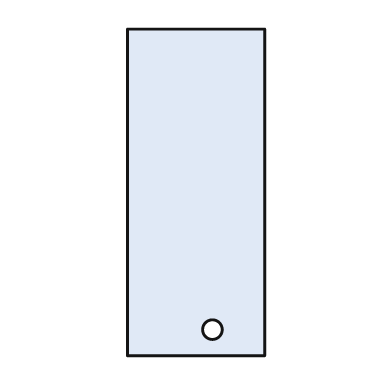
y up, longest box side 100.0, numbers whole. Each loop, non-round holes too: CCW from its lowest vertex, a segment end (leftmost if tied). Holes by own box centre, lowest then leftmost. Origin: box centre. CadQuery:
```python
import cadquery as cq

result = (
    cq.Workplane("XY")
    .moveTo(-21.0, -50.0)
    .lineTo(21.0, -50.0)
    .lineTo(21.0, 50.0)
    .lineTo(-21.0, 50.0)
    .close()
    .moveTo(5.0, -42.0)
    .circle(3.0)
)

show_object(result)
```